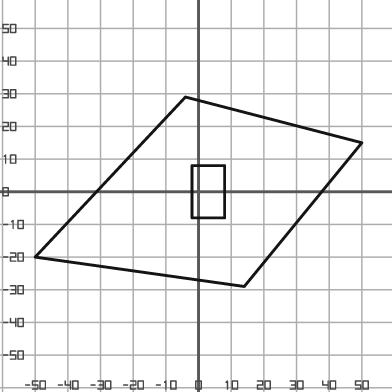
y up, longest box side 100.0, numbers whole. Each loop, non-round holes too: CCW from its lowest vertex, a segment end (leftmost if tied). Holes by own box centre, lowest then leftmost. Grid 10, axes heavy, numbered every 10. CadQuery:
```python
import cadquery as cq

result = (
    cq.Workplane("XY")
    .moveTo(14.0, -29.0)
    .lineTo(50.0, 15.0)
    .lineTo(-4.0, 29.0)
    .lineTo(-50.0, -20.0)
    .close()
    .moveTo(-2.0, -8.0)
    .lineTo(8.0, -8.0)
    .lineTo(8.0, 8.0)
    .lineTo(-2.0, 8.0)
    .close()
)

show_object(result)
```